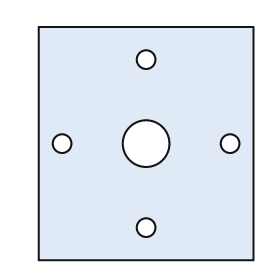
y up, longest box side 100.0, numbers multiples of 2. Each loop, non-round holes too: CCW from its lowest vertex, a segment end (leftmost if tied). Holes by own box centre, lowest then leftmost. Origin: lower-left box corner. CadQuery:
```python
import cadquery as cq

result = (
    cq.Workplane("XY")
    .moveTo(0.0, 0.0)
    .lineTo(92.0, 0.0)
    .lineTo(92.0, 100.0)
    .lineTo(0.0, 100.0)
    .close()
    .moveTo(46.0, 14.0)
    .circle(4.0)
    .moveTo(10.0, 50.0)
    .circle(4.0)
    .moveTo(46.0, 50.0)
    .circle(10.0)
    .moveTo(82.0, 50.0)
    .circle(4.0)
    .moveTo(46.0, 86.0)
    .circle(4.0)
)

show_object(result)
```